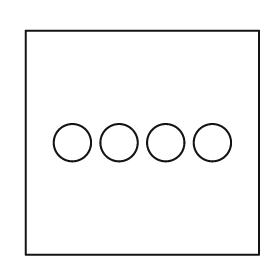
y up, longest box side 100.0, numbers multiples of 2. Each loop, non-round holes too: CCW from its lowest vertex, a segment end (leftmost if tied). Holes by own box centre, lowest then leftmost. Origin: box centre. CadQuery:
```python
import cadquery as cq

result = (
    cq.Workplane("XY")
    .moveTo(-50.0, -48.0)
    .lineTo(50.0, -48.0)
    .lineTo(50.0, 48.0)
    .lineTo(-50.0, 48.0)
    .close()
    .moveTo(-30.0, 0.0)
    .circle(8.0)
    .moveTo(-10.0, 0.0)
    .circle(8.0)
    .moveTo(10.0, 0.0)
    .circle(8.0)
    .moveTo(30.0, 0.0)
    .circle(8.0)
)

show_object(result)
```